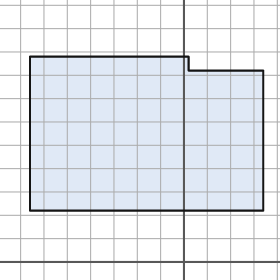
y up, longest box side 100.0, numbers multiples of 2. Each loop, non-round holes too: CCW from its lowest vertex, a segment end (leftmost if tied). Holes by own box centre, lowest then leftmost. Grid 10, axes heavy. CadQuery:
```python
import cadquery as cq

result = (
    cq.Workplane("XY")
    .moveTo(-66.0, 22.0)
    .lineTo(34.0, 22.0)
    .lineTo(34.0, 82.0)
    .lineTo(2.0, 82.0)
    .lineTo(2.0, 88.0)
    .lineTo(-66.0, 88.0)
    .close()
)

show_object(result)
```